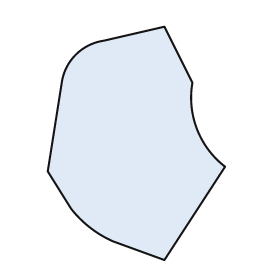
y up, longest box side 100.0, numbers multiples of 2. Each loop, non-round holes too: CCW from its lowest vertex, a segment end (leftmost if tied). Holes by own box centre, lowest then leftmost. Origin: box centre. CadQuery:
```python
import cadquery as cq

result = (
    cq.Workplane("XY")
    .moveTo(12.0, -50.0)
    .lineTo(38.0, -10.0)
    .threePointArc((26.0, 6.0), (24.0, 26.0))
    .lineTo(12.0, 50.0)
    .lineTo(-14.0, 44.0)
    .threePointArc((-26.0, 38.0), (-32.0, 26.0))
    .lineTo(-38.0, -12.0)
    .lineTo(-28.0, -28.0)
    .threePointArc((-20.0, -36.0), (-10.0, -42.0))
    .close()
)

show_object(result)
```